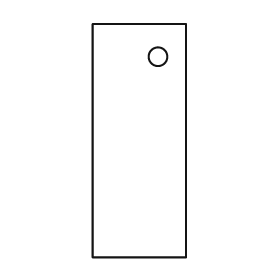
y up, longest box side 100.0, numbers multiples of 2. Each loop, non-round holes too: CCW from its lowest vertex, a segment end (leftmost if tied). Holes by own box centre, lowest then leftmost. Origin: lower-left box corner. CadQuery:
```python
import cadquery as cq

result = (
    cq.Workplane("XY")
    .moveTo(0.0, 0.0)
    .lineTo(40.0, 0.0)
    .lineTo(40.0, 100.0)
    .lineTo(0.0, 100.0)
    .close()
    .moveTo(28.0, 86.0)
    .circle(4.0)
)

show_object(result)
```